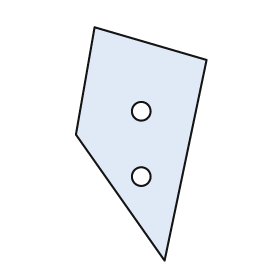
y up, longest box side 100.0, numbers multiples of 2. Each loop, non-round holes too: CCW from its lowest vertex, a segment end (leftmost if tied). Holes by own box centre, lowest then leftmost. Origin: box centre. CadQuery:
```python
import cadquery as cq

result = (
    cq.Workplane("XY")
    .moveTo(10.0, -50.0)
    .lineTo(28.0, 36.0)
    .lineTo(-20.0, 50.0)
    .lineTo(-28.0, 4.0)
    .close()
    .moveTo(0.0, -14.0)
    .circle(4.0)
    .moveTo(0.0, 14.0)
    .circle(4.0)
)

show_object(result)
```